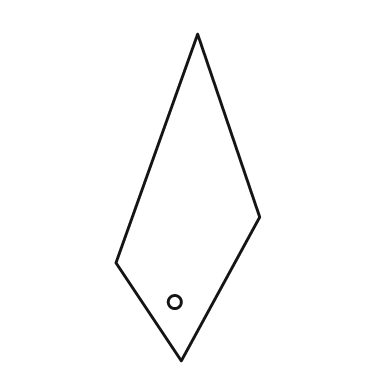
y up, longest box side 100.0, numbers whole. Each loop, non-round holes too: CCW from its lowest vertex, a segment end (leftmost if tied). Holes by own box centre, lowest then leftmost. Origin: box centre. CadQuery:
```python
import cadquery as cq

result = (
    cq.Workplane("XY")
    .moveTo(-2.0, -50.0)
    .lineTo(22.0, -6.0)
    .lineTo(3.0, 50.0)
    .lineTo(-22.0, -20.0)
    .close()
    .moveTo(-4.0, -32.0)
    .circle(2.0)
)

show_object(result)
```